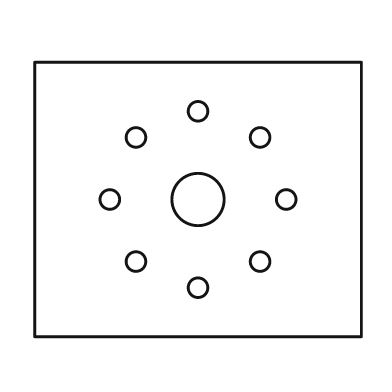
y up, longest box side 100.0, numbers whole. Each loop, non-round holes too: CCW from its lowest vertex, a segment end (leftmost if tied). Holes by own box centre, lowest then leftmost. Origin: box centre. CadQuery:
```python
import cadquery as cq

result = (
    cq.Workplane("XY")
    .moveTo(-50.0, -42.0)
    .lineTo(50.0, -42.0)
    .lineTo(50.0, 42.0)
    .lineTo(-50.0, 42.0)
    .close()
    .moveTo(0.0, -27.0)
    .circle(3.0)
    .moveTo(-19.0, -19.0)
    .circle(3.0)
    .moveTo(19.0, -19.0)
    .circle(3.0)
    .moveTo(-27.0, 0.0)
    .circle(3.0)
    .moveTo(0.0, 0.0)
    .circle(8.0)
    .moveTo(27.0, 0.0)
    .circle(3.0)
    .moveTo(-19.0, 19.0)
    .circle(3.0)
    .moveTo(19.0, 19.0)
    .circle(3.0)
    .moveTo(0.0, 27.0)
    .circle(3.0)
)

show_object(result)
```